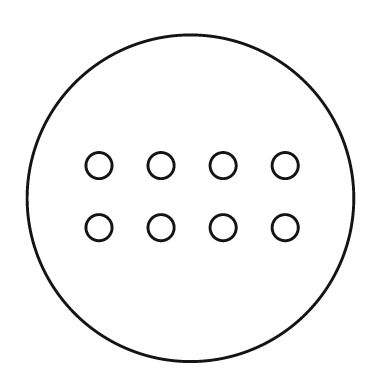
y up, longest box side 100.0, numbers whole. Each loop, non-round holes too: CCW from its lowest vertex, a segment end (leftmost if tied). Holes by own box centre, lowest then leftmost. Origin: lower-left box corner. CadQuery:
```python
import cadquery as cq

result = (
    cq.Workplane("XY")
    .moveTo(50.0, 50.0)
    .circle(50.0)
    .moveTo(22.0, 41.0)
    .circle(4.0)
    .moveTo(41.0, 41.0)
    .circle(4.0)
    .moveTo(60.0, 41.0)
    .circle(4.0)
    .moveTo(79.0, 41.0)
    .circle(4.0)
    .moveTo(22.0, 60.0)
    .circle(4.0)
    .moveTo(41.0, 60.0)
    .circle(4.0)
    .moveTo(60.0, 60.0)
    .circle(4.0)
    .moveTo(79.0, 60.0)
    .circle(4.0)
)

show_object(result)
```